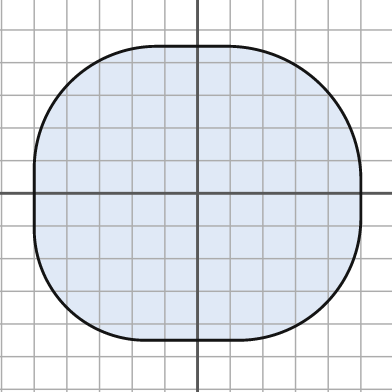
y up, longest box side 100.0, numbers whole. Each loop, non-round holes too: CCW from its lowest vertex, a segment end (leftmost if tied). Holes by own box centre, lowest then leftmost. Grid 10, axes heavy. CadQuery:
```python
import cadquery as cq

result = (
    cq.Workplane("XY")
    .moveTo(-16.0, -45.0)
    .lineTo(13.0, -45.0)
    .threePointArc((39.0, -34.0), (50.0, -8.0))
    .lineTo(50.0, 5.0)
    .threePointArc((38.0, 33.0), (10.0, 45.0))
    .lineTo(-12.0, 45.0)
    .threePointArc((-39.0, 34.0), (-50.0, 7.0))
    .lineTo(-50.0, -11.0)
    .threePointArc((-40.0, -35.0), (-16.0, -45.0))
    .close()
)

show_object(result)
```